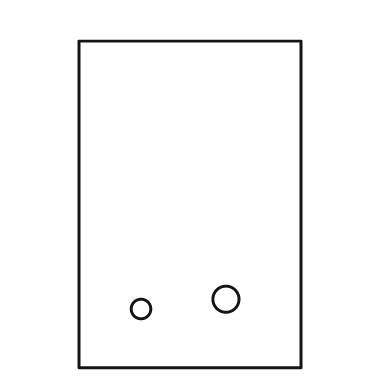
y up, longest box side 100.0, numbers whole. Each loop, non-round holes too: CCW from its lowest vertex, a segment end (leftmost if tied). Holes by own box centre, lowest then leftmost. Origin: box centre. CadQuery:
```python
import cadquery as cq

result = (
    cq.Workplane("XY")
    .moveTo(-34.0, -50.0)
    .lineTo(34.0, -50.0)
    .lineTo(34.0, 50.0)
    .lineTo(-34.0, 50.0)
    .close()
    .moveTo(-15.0, -32.0)
    .circle(3.0)
    .moveTo(11.0, -29.0)
    .circle(4.0)
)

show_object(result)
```